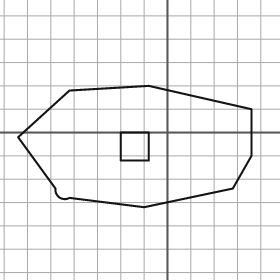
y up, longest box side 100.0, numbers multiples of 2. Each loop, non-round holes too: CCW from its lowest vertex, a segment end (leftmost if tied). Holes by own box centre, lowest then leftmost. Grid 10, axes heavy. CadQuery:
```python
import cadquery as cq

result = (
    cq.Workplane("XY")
    .moveTo(-10.0, -32.0)
    .lineTo(28.0, -24.0)
    .lineTo(36.0, -10.0)
    .lineTo(36.0, 10.0)
    .lineTo(-8.0, 20.0)
    .lineTo(-42.0, 18.0)
    .lineTo(-64.0, -2.0)
    .lineTo(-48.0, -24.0)
    .threePointArc((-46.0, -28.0), (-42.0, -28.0))
    .close()
    .moveTo(-20.0, -12.0)
    .lineTo(-8.0, -12.0)
    .lineTo(-8.0, 0.0)
    .lineTo(-20.0, 0.0)
    .close()
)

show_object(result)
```